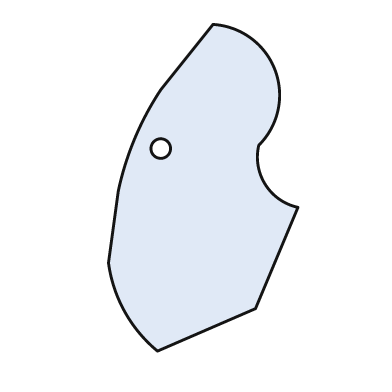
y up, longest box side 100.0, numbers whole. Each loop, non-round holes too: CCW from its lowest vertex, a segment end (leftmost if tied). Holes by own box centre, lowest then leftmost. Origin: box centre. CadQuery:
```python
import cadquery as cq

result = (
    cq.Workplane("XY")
    .moveTo(-14.0, -50.0)
    .lineTo(16.0, -37.0)
    .lineTo(29.0, -6.0)
    .threePointArc((19.0, 1.0), (17.0, 13.0))
    .threePointArc((22.0, 36.0), (3.0, 50.0))
    .lineTo(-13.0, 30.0)
    .threePointArc((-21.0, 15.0), (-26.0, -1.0))
    .lineTo(-29.0, -23.0)
    .threePointArc((-24.0, -38.0), (-14.0, -50.0))
    .close()
    .moveTo(-13.0, 12.0)
    .circle(3.0)
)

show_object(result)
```